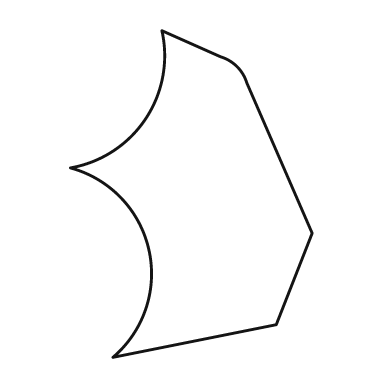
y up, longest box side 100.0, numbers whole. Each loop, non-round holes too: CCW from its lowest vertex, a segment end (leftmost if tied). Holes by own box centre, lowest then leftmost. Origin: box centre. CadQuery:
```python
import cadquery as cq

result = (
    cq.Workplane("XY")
    .moveTo(-24.0, -50.0)
    .lineTo(26.0, -40.0)
    .lineTo(37.0, -12.0)
    .lineTo(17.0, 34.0)
    .threePointArc((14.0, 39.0), (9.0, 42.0))
    .lineTo(-9.0, 50.0)
    .threePointArc((-14.0, 23.0), (-37.0, 8.0))
    .threePointArc((-13.0, -17.0), (-24.0, -50.0))
    .close()
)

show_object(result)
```